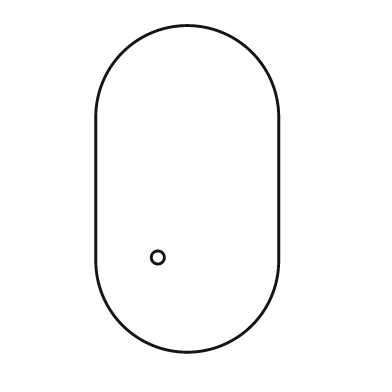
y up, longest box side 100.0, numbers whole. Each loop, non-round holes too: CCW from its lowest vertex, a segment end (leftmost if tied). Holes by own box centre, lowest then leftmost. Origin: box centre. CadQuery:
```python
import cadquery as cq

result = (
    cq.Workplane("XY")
    .moveTo(-28.0, -22.0)
    .threePointArc((0.0, -50.0), (28.0, -22.0))
    .lineTo(28.0, 22.0)
    .threePointArc((0.0, 50.0), (-28.0, 22.0))
    .close()
    .moveTo(-9.0, -21.0)
    .circle(2.0)
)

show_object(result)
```